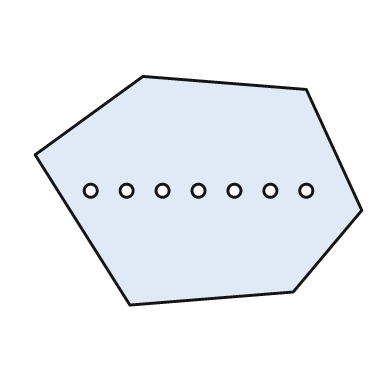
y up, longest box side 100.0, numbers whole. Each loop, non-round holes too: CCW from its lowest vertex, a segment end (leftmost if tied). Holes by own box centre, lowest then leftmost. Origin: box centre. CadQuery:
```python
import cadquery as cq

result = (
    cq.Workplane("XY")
    .moveTo(-21.0, -35.0)
    .lineTo(29.0, -31.0)
    .lineTo(50.0, -6.0)
    .lineTo(33.0, 31.0)
    .lineTo(-17.0, 35.0)
    .lineTo(-50.0, 11.0)
    .close()
    .moveTo(-33.0, 0.0)
    .circle(2.0)
    .moveTo(-22.0, 0.0)
    .circle(2.0)
    .moveTo(-11.0, 0.0)
    .circle(2.0)
    .moveTo(0.0, 0.0)
    .circle(2.0)
    .moveTo(11.0, 0.0)
    .circle(2.0)
    .moveTo(22.0, 0.0)
    .circle(2.0)
    .moveTo(33.0, 0.0)
    .circle(2.0)
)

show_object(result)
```